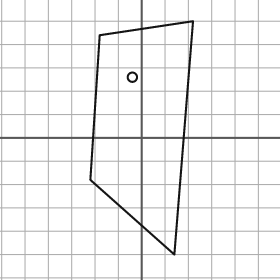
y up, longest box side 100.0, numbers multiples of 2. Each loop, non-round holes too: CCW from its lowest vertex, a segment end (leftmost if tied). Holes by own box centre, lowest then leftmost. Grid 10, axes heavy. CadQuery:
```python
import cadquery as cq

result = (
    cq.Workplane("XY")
    .moveTo(14.0, -50.0)
    .lineTo(22.0, 50.0)
    .lineTo(-18.0, 44.0)
    .lineTo(-22.0, -18.0)
    .close()
    .moveTo(-4.0, 26.0)
    .circle(2.0)
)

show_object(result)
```